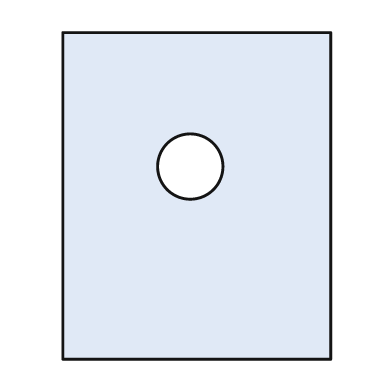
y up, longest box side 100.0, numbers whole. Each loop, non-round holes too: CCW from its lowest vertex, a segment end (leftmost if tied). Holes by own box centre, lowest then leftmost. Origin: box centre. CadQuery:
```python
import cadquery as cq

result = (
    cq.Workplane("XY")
    .moveTo(-41.0, -50.0)
    .lineTo(41.0, -50.0)
    .lineTo(41.0, 50.0)
    .lineTo(-41.0, 50.0)
    .close()
    .moveTo(-2.0, 9.0)
    .circle(10.0)
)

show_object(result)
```